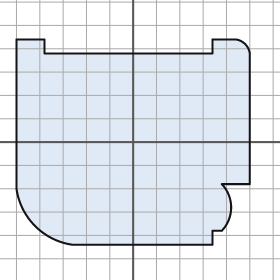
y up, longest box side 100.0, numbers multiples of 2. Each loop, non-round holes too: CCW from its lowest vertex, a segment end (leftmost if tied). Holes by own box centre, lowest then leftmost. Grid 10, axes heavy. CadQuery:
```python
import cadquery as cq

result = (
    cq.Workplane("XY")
    .moveTo(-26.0, -44.0)
    .lineTo(34.0, -44.0)
    .lineTo(34.0, -38.0)
    .lineTo(38.0, -38.0)
    .threePointArc((42.0, -28.0), (38.0, -18.0))
    .lineTo(50.0, -18.0)
    .lineTo(50.0, 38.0)
    .threePointArc((48.0, 42.0), (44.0, 44.0))
    .lineTo(34.0, 44.0)
    .lineTo(34.0, 38.0)
    .lineTo(-38.0, 38.0)
    .lineTo(-38.0, 44.0)
    .lineTo(-50.0, 44.0)
    .lineTo(-50.0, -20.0)
    .threePointArc((-42.0, -36.0), (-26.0, -44.0))
    .close()
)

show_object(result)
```